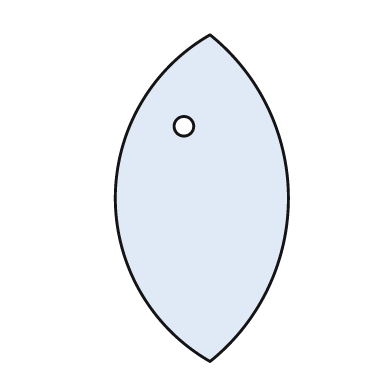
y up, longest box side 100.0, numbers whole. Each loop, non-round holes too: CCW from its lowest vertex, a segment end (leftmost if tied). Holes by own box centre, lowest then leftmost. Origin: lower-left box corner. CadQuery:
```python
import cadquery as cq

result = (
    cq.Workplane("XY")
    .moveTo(29.0, 0.0)
    .threePointArc((53.0, 50.0), (29.0, 100.0))
    .threePointArc((0.0, 50.0), (29.0, 0.0))
    .close()
    .moveTo(21.0, 72.0)
    .circle(3.0)
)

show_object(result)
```